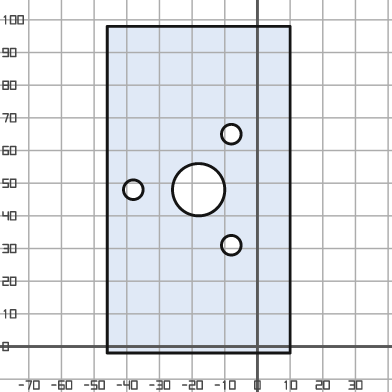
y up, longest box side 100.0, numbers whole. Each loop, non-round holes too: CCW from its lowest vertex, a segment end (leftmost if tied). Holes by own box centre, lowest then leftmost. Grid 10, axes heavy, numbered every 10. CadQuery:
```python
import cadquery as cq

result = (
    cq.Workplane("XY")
    .moveTo(-46.0, -2.0)
    .lineTo(10.0, -2.0)
    .lineTo(10.0, 98.0)
    .lineTo(-46.0, 98.0)
    .close()
    .moveTo(-8.0, 31.0)
    .circle(3.0)
    .moveTo(-38.0, 48.0)
    .circle(3.0)
    .moveTo(-18.0, 48.0)
    .circle(8.0)
    .moveTo(-8.0, 65.0)
    .circle(3.0)
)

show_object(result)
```